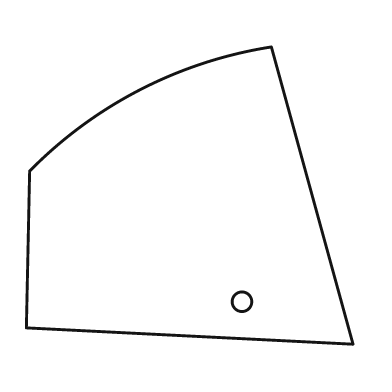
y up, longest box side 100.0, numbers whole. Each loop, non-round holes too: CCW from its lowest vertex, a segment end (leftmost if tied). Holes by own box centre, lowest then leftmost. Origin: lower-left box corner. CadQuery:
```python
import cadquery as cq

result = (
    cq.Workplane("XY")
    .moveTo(100.0, 0.0)
    .lineTo(75.0, 91.0)
    .threePointArc((35.0, 78.0), (1.0, 53.0))
    .lineTo(0.0, 5.0)
    .close()
    .moveTo(66.0, 13.0)
    .circle(3.0)
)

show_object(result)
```